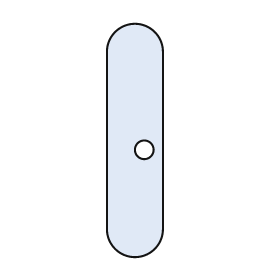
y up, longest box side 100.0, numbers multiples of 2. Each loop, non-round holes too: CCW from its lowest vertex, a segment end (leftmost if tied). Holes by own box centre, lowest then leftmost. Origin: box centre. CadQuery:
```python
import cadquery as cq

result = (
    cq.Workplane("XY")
    .moveTo(-12.0, -38.0)
    .threePointArc((0.0, -50.0), (12.0, -38.0))
    .lineTo(12.0, 38.0)
    .threePointArc((0.0, 50.0), (-12.0, 38.0))
    .close()
    .moveTo(4.0, -4.0)
    .circle(4.0)
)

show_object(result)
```